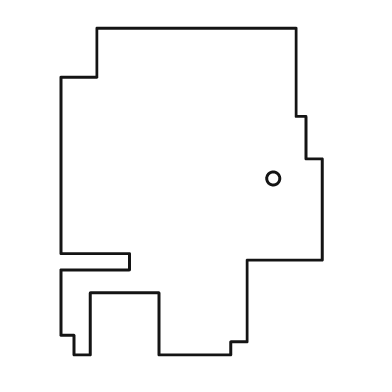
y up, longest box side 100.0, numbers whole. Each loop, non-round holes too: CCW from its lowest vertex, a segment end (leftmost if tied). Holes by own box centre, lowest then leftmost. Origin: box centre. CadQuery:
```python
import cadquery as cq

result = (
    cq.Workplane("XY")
    .moveTo(-36.0, -50.0)
    .lineTo(-31.0, -50.0)
    .lineTo(-31.0, -31.0)
    .lineTo(-10.0, -31.0)
    .lineTo(-10.0, -50.0)
    .lineTo(12.0, -50.0)
    .lineTo(12.0, -46.0)
    .lineTo(17.0, -46.0)
    .lineTo(17.0, -21.0)
    .lineTo(40.0, -21.0)
    .lineTo(40.0, 10.0)
    .lineTo(35.0, 10.0)
    .lineTo(35.0, 23.0)
    .lineTo(32.0, 23.0)
    .lineTo(32.0, 50.0)
    .lineTo(-29.0, 50.0)
    .lineTo(-29.0, 35.0)
    .lineTo(-40.0, 35.0)
    .lineTo(-40.0, -19.0)
    .lineTo(-19.0, -19.0)
    .lineTo(-19.0, -24.0)
    .lineTo(-40.0, -24.0)
    .lineTo(-40.0, -44.0)
    .lineTo(-36.0, -44.0)
    .close()
    .moveTo(25.0, 4.0)
    .circle(2.0)
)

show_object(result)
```